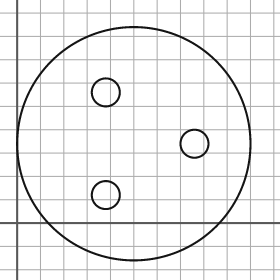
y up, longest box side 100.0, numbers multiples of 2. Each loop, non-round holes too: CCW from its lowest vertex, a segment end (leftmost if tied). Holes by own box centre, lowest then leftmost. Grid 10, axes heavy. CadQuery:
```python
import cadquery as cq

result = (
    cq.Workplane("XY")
    .moveTo(50.0, 34.0)
    .circle(50.0)
    .moveTo(38.0, 12.0)
    .circle(6.0)
    .moveTo(76.0, 34.0)
    .circle(6.0)
    .moveTo(38.0, 56.0)
    .circle(6.0)
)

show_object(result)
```